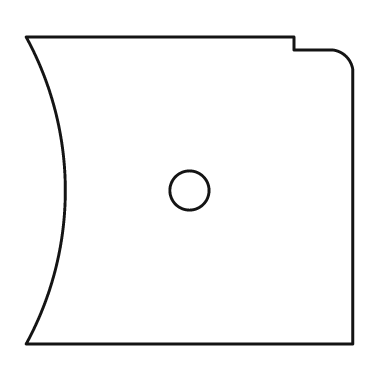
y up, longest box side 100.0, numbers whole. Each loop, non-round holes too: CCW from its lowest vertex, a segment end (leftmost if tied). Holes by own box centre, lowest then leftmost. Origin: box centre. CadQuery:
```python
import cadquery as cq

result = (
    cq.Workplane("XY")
    .moveTo(-50.0, -47.0)
    .lineTo(50.0, -47.0)
    .lineTo(50.0, 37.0)
    .threePointArc((48.0, 41.0), (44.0, 43.0))
    .lineTo(32.0, 43.0)
    .lineTo(32.0, 47.0)
    .lineTo(-50.0, 47.0)
    .threePointArc((-38.0, 0.0), (-50.0, -47.0))
    .close()
    .moveTo(0.0, 0.0)
    .circle(6.0)
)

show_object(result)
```